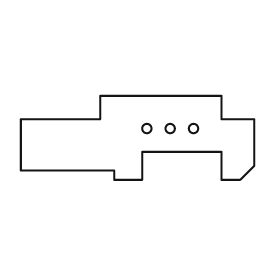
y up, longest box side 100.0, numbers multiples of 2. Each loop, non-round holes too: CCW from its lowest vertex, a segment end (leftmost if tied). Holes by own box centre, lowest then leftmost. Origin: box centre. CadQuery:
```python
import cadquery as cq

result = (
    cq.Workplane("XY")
    .moveTo(-10.0, -18.0)
    .lineTo(2.0, -18.0)
    .lineTo(2.0, -6.0)
    .lineTo(36.0, -6.0)
    .lineTo(36.0, -18.0)
    .lineTo(44.0, -18.0)
    .lineTo(50.0, -12.0)
    .lineTo(50.0, 8.0)
    .lineTo(36.0, 8.0)
    .lineTo(36.0, 18.0)
    .lineTo(-16.0, 18.0)
    .lineTo(-16.0, 8.0)
    .lineTo(-50.0, 8.0)
    .lineTo(-50.0, -14.0)
    .lineTo(-10.0, -14.0)
    .close()
    .moveTo(4.0, 4.0)
    .circle(2.0)
    .moveTo(14.0, 4.0)
    .circle(2.0)
    .moveTo(24.0, 4.0)
    .circle(2.0)
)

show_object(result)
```